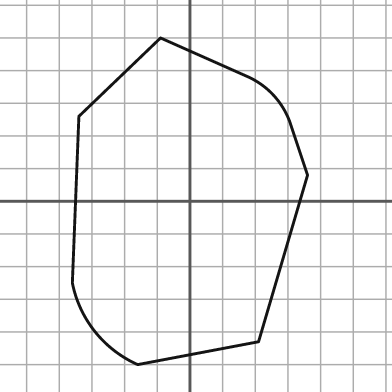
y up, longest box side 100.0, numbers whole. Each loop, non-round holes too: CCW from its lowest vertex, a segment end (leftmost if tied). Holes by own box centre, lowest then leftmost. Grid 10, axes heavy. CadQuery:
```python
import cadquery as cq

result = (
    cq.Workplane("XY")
    .moveTo(-16.0, -50.0)
    .lineTo(21.0, -43.0)
    .lineTo(36.0, 8.0)
    .lineTo(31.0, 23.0)
    .threePointArc((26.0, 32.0), (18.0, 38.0))
    .lineTo(-9.0, 50.0)
    .lineTo(-34.0, 26.0)
    .lineTo(-36.0, -25.0)
    .threePointArc((-29.0, -40.0), (-16.0, -50.0))
    .close()
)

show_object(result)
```